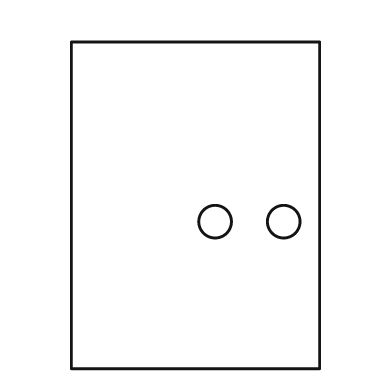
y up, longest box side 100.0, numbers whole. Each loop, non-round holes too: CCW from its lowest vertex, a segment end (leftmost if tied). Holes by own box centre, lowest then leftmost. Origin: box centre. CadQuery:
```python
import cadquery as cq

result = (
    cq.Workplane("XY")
    .moveTo(-38.0, -50.0)
    .lineTo(38.0, -50.0)
    .lineTo(38.0, 50.0)
    .lineTo(-38.0, 50.0)
    .close()
    .moveTo(6.0, -5.0)
    .circle(5.0)
    .moveTo(27.0, -5.0)
    .circle(5.0)
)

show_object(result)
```